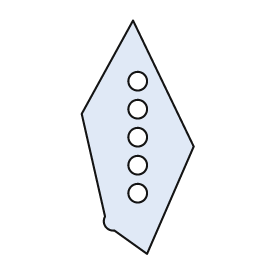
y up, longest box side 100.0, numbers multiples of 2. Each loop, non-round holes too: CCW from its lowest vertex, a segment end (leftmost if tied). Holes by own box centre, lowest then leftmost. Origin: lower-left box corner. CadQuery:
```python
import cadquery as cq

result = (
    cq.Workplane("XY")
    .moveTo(28.0, 0.0)
    .lineTo(48.0, 46.0)
    .lineTo(22.0, 100.0)
    .lineTo(0.0, 60.0)
    .lineTo(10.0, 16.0)
    .threePointArc((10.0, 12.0), (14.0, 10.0))
    .close()
    .moveTo(24.0, 26.0)
    .circle(4.0)
    .moveTo(24.0, 38.0)
    .circle(4.0)
    .moveTo(24.0, 50.0)
    .circle(4.0)
    .moveTo(24.0, 62.0)
    .circle(4.0)
    .moveTo(24.0, 74.0)
    .circle(4.0)
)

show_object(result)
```